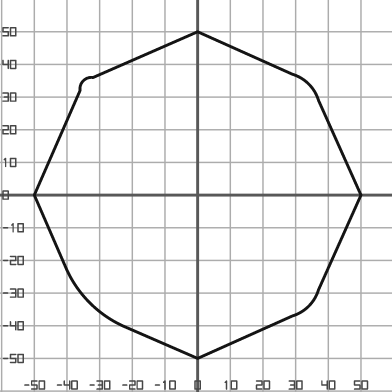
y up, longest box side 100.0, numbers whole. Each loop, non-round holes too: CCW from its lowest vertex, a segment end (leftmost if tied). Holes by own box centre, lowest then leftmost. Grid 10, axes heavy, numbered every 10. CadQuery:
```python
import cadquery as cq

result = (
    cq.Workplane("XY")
    .moveTo(0.0, -50.0)
    .lineTo(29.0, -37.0)
    .threePointArc((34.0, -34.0), (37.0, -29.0))
    .lineTo(50.0, 0.0)
    .lineTo(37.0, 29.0)
    .threePointArc((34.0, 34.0), (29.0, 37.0))
    .lineTo(0.0, 50.0)
    .lineTo(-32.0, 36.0)
    .threePointArc((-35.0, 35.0), (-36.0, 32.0))
    .lineTo(-50.0, 0.0)
    .lineTo(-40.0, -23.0)
    .threePointArc((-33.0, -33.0), (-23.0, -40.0))
    .close()
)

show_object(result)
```